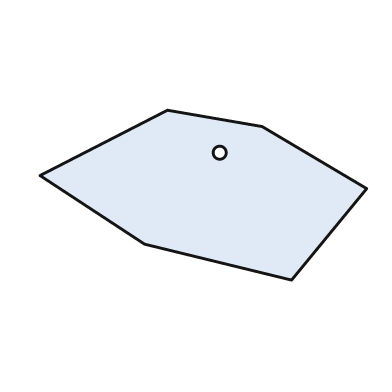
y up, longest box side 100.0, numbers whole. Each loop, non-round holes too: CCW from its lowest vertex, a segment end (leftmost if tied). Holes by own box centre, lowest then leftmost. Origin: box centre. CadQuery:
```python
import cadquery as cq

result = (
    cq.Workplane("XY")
    .moveTo(27.0, -26.0)
    .lineTo(50.0, 2.0)
    .lineTo(18.0, 21.0)
    .lineTo(-11.0, 26.0)
    .lineTo(-50.0, 6.0)
    .lineTo(-18.0, -15.0)
    .close()
    .moveTo(5.0, 13.0)
    .circle(2.0)
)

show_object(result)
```